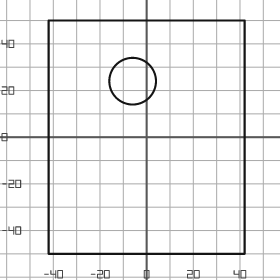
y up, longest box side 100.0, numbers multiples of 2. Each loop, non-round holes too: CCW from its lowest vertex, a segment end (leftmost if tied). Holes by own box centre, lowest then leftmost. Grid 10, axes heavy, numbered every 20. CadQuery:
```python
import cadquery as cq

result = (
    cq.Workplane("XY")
    .moveTo(-42.0, -50.0)
    .lineTo(42.0, -50.0)
    .lineTo(42.0, 50.0)
    .lineTo(-42.0, 50.0)
    .close()
    .moveTo(-6.0, 24.0)
    .circle(10.0)
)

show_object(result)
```